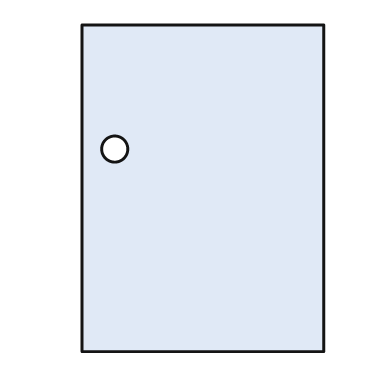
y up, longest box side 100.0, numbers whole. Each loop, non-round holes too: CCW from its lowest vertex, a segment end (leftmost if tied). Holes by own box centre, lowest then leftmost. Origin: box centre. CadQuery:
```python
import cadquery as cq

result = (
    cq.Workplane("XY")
    .moveTo(-37.0, -50.0)
    .lineTo(37.0, -50.0)
    .lineTo(37.0, 50.0)
    .lineTo(-37.0, 50.0)
    .close()
    .moveTo(-27.0, 12.0)
    .circle(4.0)
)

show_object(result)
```